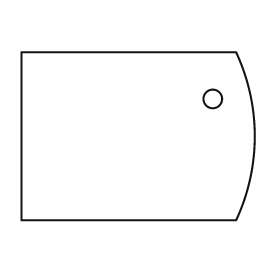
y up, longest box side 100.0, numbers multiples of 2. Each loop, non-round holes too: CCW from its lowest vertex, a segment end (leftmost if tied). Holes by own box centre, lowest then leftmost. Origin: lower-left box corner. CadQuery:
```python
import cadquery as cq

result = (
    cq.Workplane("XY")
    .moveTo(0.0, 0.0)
    .lineTo(92.0, 0.0)
    .threePointArc((100.0, 36.0), (92.0, 72.0))
    .lineTo(0.0, 72.0)
    .close()
    .moveTo(82.0, 52.0)
    .circle(4.0)
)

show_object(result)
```